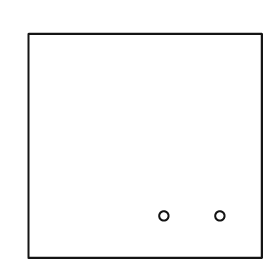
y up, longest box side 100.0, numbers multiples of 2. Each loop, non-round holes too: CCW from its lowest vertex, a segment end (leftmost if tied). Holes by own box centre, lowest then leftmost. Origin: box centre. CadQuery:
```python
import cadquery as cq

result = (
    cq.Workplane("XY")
    .moveTo(-50.0, -48.0)
    .lineTo(50.0, -48.0)
    .lineTo(50.0, 48.0)
    .lineTo(-50.0, 48.0)
    .close()
    .moveTo(8.0, -30.0)
    .circle(2.0)
    .moveTo(32.0, -30.0)
    .circle(2.0)
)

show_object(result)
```